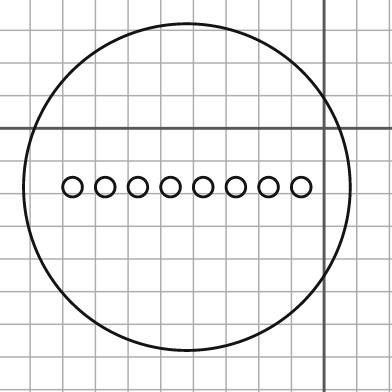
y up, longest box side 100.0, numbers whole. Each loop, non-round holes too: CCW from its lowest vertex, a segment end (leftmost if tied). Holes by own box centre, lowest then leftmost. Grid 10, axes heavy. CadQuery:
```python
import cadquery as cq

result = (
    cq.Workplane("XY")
    .moveTo(-42.0, -18.0)
    .circle(50.0)
    .moveTo(-77.0, -18.0)
    .circle(3.0)
    .moveTo(-67.0, -18.0)
    .circle(3.0)
    .moveTo(-57.0, -18.0)
    .circle(3.0)
    .moveTo(-47.0, -18.0)
    .circle(3.0)
    .moveTo(-37.0, -18.0)
    .circle(3.0)
    .moveTo(-27.0, -18.0)
    .circle(3.0)
    .moveTo(-17.0, -18.0)
    .circle(3.0)
    .moveTo(-7.0, -18.0)
    .circle(3.0)
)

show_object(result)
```